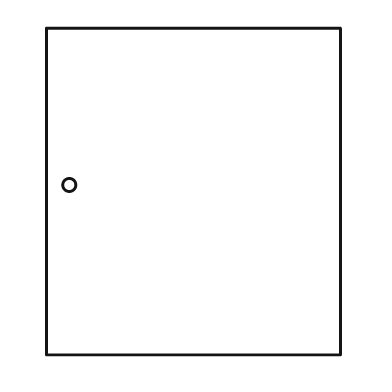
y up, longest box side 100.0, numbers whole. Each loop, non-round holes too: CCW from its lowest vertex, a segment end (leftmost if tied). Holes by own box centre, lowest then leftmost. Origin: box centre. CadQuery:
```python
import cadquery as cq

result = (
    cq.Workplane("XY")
    .moveTo(-45.0, -50.0)
    .lineTo(45.0, -50.0)
    .lineTo(45.0, 50.0)
    .lineTo(-45.0, 50.0)
    .close()
    .moveTo(-38.0, 2.0)
    .circle(2.0)
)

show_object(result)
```